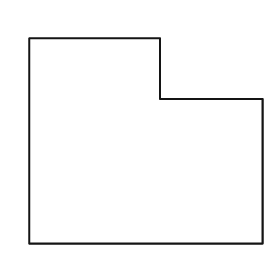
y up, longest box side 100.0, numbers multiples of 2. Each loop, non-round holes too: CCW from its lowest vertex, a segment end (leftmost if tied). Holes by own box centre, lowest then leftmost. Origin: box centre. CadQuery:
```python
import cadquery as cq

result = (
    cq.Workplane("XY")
    .moveTo(-50.0, -44.0)
    .lineTo(50.0, -44.0)
    .lineTo(50.0, 18.0)
    .lineTo(6.0, 18.0)
    .lineTo(6.0, 44.0)
    .lineTo(-50.0, 44.0)
    .close()
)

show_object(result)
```